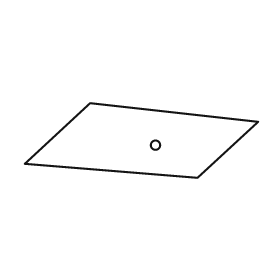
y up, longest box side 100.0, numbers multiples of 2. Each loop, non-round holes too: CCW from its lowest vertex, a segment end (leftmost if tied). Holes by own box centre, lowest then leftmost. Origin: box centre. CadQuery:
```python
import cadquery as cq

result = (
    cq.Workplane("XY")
    .moveTo(24.0, -16.0)
    .lineTo(50.0, 8.0)
    .lineTo(-22.0, 16.0)
    .lineTo(-50.0, -10.0)
    .close()
    .moveTo(6.0, -2.0)
    .circle(2.0)
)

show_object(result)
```